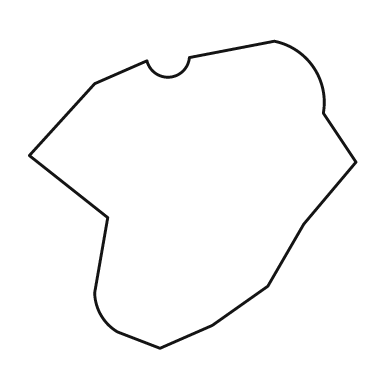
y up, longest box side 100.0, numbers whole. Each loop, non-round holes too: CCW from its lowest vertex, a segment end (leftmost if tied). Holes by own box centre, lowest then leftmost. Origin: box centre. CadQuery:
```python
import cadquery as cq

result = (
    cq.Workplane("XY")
    .moveTo(-10.0, -47.0)
    .lineTo(6.0, -40.0)
    .lineTo(23.0, -28.0)
    .lineTo(34.0, -9.0)
    .lineTo(50.0, 10.0)
    .lineTo(40.0, 25.0)
    .threePointArc((37.0, 39.0), (25.0, 47.0))
    .lineTo(-1.0, 42.0)
    .threePointArc((-7.0, 36.0), (-14.0, 41.0))
    .lineTo(-30.0, 34.0)
    .lineTo(-50.0, 12.0)
    .lineTo(-26.0, -7.0)
    .lineTo(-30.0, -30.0)
    .threePointArc((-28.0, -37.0), (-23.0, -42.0))
    .close()
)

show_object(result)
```